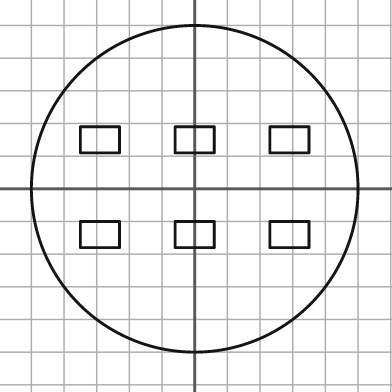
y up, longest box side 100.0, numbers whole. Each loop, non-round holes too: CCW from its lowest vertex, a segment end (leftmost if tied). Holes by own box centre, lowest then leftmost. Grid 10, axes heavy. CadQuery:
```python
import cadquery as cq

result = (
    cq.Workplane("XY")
    .moveTo(0.0, 0.0)
    .circle(50.0)
    .moveTo(-35.0, -18.0)
    .lineTo(-23.0, -18.0)
    .lineTo(-23.0, -10.0)
    .lineTo(-35.0, -10.0)
    .close()
    .moveTo(-6.0, -18.0)
    .lineTo(6.0, -18.0)
    .lineTo(6.0, -10.0)
    .lineTo(-6.0, -10.0)
    .close()
    .moveTo(23.0, -18.0)
    .lineTo(35.0, -18.0)
    .lineTo(35.0, -10.0)
    .lineTo(23.0, -10.0)
    .close()
    .moveTo(-35.0, 11.0)
    .lineTo(-23.0, 11.0)
    .lineTo(-23.0, 19.0)
    .lineTo(-35.0, 19.0)
    .close()
    .moveTo(-6.0, 11.0)
    .lineTo(6.0, 11.0)
    .lineTo(6.0, 19.0)
    .lineTo(-6.0, 19.0)
    .close()
    .moveTo(23.0, 11.0)
    .lineTo(35.0, 11.0)
    .lineTo(35.0, 19.0)
    .lineTo(23.0, 19.0)
    .close()
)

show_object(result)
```